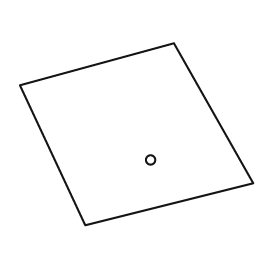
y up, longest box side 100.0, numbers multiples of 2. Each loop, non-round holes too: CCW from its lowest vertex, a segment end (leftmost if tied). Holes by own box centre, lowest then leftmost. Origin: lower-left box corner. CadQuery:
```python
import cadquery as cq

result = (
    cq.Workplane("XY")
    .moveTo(28.0, 0.0)
    .lineTo(100.0, 18.0)
    .lineTo(66.0, 78.0)
    .lineTo(0.0, 60.0)
    .close()
    .moveTo(56.0, 28.0)
    .circle(2.0)
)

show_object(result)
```